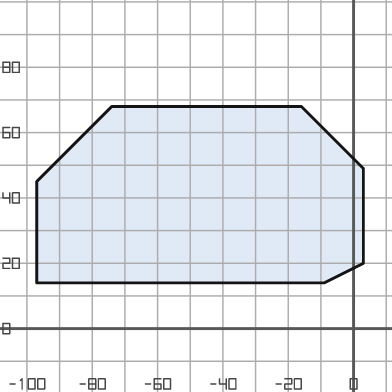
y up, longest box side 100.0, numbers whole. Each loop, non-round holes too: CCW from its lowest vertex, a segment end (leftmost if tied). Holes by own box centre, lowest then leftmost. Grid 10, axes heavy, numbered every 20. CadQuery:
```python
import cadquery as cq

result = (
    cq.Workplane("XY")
    .moveTo(-97.0, 14.0)
    .lineTo(-9.0, 14.0)
    .lineTo(3.0, 20.0)
    .lineTo(3.0, 49.0)
    .lineTo(-16.0, 68.0)
    .lineTo(-74.0, 68.0)
    .lineTo(-97.0, 45.0)
    .close()
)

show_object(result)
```